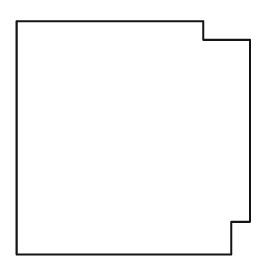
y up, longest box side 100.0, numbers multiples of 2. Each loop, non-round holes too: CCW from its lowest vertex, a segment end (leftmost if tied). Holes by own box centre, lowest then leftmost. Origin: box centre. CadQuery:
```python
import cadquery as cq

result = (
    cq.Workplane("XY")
    .moveTo(-50.0, -50.0)
    .lineTo(42.0, -50.0)
    .lineTo(42.0, -36.0)
    .lineTo(50.0, -36.0)
    .lineTo(50.0, 42.0)
    .lineTo(30.0, 42.0)
    .lineTo(30.0, 50.0)
    .lineTo(-50.0, 50.0)
    .close()
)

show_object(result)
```